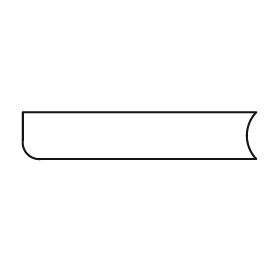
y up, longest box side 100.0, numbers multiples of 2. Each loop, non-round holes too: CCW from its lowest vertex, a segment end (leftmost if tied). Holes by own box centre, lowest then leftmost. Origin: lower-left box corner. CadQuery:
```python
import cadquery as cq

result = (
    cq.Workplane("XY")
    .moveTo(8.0, 0.0)
    .lineTo(100.0, 0.0)
    .threePointArc((96.0, 10.0), (100.0, 20.0))
    .lineTo(0.0, 20.0)
    .lineTo(0.0, 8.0)
    .threePointArc((2.0, 2.0), (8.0, 0.0))
    .close()
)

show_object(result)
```